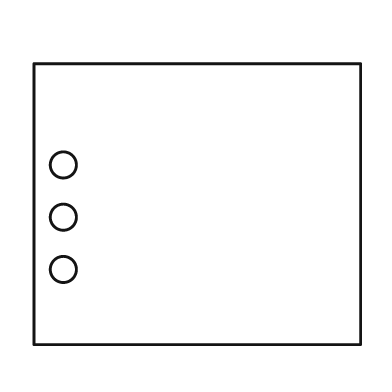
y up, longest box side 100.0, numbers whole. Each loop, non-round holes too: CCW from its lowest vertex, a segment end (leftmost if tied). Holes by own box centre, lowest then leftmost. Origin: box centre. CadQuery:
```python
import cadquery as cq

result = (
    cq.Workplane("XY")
    .moveTo(-50.0, -43.0)
    .lineTo(50.0, -43.0)
    .lineTo(50.0, 43.0)
    .lineTo(-50.0, 43.0)
    .close()
    .moveTo(-41.0, -20.0)
    .circle(4.0)
    .moveTo(-41.0, -4.0)
    .circle(4.0)
    .moveTo(-41.0, 12.0)
    .circle(4.0)
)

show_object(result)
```